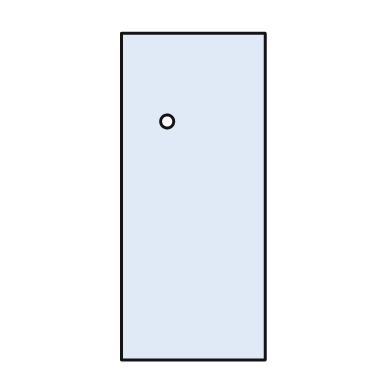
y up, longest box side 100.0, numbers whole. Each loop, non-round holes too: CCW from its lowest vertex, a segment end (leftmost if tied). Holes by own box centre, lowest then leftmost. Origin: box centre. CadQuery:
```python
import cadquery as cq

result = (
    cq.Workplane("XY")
    .moveTo(-22.0, -50.0)
    .lineTo(22.0, -50.0)
    .lineTo(22.0, 50.0)
    .lineTo(-22.0, 50.0)
    .close()
    .moveTo(-8.0, 23.0)
    .circle(2.0)
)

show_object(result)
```